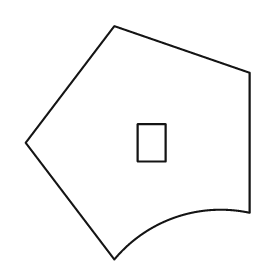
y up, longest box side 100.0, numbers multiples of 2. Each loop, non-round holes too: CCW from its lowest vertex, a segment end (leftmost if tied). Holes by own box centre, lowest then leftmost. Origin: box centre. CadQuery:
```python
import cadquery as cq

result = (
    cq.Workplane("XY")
    .moveTo(-10.0, -50.0)
    .threePointArc((16.0, -32.0), (48.0, -30.0))
    .lineTo(48.0, 30.0)
    .lineTo(-10.0, 50.0)
    .lineTo(-48.0, 0.0)
    .close()
    .moveTo(0.0, -8.0)
    .lineTo(12.0, -8.0)
    .lineTo(12.0, 8.0)
    .lineTo(0.0, 8.0)
    .close()
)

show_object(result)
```